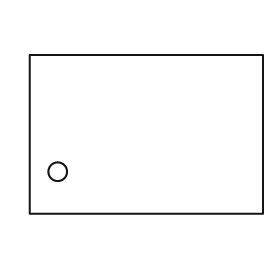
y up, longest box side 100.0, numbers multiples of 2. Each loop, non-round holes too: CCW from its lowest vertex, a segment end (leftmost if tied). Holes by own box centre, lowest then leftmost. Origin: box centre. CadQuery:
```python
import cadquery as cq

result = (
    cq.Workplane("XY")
    .moveTo(-50.0, -34.0)
    .lineTo(50.0, -34.0)
    .lineTo(50.0, 34.0)
    .lineTo(-50.0, 34.0)
    .close()
    .moveTo(-38.0, -16.0)
    .circle(4.0)
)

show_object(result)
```